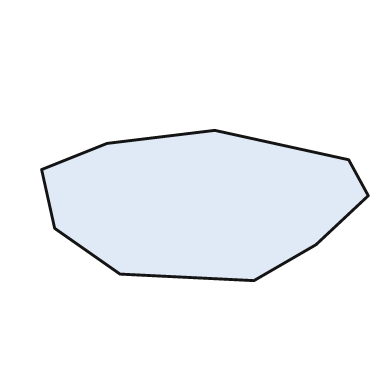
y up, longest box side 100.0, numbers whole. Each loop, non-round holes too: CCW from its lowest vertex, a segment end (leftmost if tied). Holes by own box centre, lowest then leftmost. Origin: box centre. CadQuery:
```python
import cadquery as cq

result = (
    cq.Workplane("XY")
    .moveTo(15.0, -23.0)
    .lineTo(34.0, -12.0)
    .lineTo(50.0, 3.0)
    .lineTo(44.0, 14.0)
    .lineTo(3.0, 23.0)
    .lineTo(-30.0, 19.0)
    .lineTo(-50.0, 11.0)
    .lineTo(-46.0, -7.0)
    .lineTo(-26.0, -21.0)
    .close()
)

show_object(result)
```